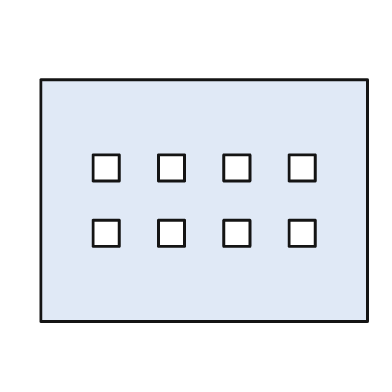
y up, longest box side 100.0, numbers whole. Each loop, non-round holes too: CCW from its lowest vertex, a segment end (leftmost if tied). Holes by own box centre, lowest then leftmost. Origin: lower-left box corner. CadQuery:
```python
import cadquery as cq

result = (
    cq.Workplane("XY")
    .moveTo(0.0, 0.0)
    .lineTo(100.0, 0.0)
    .lineTo(100.0, 74.0)
    .lineTo(0.0, 74.0)
    .close()
    .moveTo(16.0, 23.0)
    .lineTo(24.0, 23.0)
    .lineTo(24.0, 31.0)
    .lineTo(16.0, 31.0)
    .close()
    .moveTo(36.0, 23.0)
    .lineTo(44.0, 23.0)
    .lineTo(44.0, 31.0)
    .lineTo(36.0, 31.0)
    .close()
    .moveTo(56.0, 23.0)
    .lineTo(64.0, 23.0)
    .lineTo(64.0, 31.0)
    .lineTo(56.0, 31.0)
    .close()
    .moveTo(76.0, 23.0)
    .lineTo(84.0, 23.0)
    .lineTo(84.0, 31.0)
    .lineTo(76.0, 31.0)
    .close()
    .moveTo(16.0, 43.0)
    .lineTo(24.0, 43.0)
    .lineTo(24.0, 51.0)
    .lineTo(16.0, 51.0)
    .close()
    .moveTo(36.0, 43.0)
    .lineTo(44.0, 43.0)
    .lineTo(44.0, 51.0)
    .lineTo(36.0, 51.0)
    .close()
    .moveTo(56.0, 43.0)
    .lineTo(64.0, 43.0)
    .lineTo(64.0, 51.0)
    .lineTo(56.0, 51.0)
    .close()
    .moveTo(76.0, 43.0)
    .lineTo(84.0, 43.0)
    .lineTo(84.0, 51.0)
    .lineTo(76.0, 51.0)
    .close()
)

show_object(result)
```